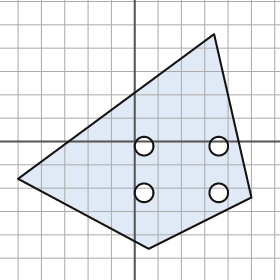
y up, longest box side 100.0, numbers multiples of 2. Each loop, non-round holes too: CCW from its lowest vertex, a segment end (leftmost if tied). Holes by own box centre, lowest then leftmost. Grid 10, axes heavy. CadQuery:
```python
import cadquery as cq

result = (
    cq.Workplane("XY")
    .moveTo(6.0, -46.0)
    .lineTo(50.0, -24.0)
    .lineTo(34.0, 46.0)
    .lineTo(-50.0, -16.0)
    .close()
    .moveTo(4.0, -22.0)
    .circle(4.0)
    .moveTo(36.0, -22.0)
    .circle(4.0)
    .moveTo(4.0, -2.0)
    .circle(4.0)
    .moveTo(36.0, -2.0)
    .circle(4.0)
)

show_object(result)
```